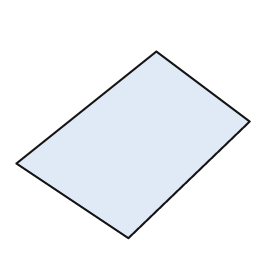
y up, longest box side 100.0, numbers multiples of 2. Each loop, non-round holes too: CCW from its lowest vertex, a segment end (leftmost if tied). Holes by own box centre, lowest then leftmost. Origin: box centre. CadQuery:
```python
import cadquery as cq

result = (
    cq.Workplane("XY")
    .moveTo(-2.0, -40.0)
    .lineTo(50.0, 10.0)
    .lineTo(10.0, 40.0)
    .lineTo(-50.0, -8.0)
    .close()
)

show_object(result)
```